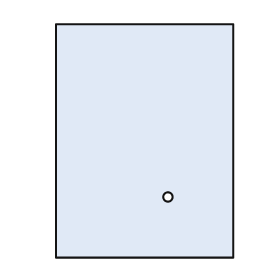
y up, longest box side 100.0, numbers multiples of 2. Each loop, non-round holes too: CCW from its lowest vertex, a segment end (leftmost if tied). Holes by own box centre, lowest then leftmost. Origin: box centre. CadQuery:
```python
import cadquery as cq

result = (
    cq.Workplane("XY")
    .moveTo(-38.0, -50.0)
    .lineTo(38.0, -50.0)
    .lineTo(38.0, 50.0)
    .lineTo(-38.0, 50.0)
    .close()
    .moveTo(10.0, -24.0)
    .circle(2.0)
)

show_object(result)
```